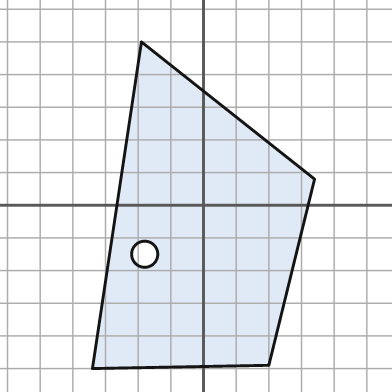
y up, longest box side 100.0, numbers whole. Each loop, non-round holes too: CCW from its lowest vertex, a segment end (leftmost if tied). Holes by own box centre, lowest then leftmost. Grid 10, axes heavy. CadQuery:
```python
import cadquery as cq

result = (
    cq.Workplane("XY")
    .moveTo(-34.0, -50.0)
    .lineTo(20.0, -49.0)
    .lineTo(34.0, 8.0)
    .lineTo(-19.0, 50.0)
    .close()
    .moveTo(-18.0, -15.0)
    .circle(4.0)
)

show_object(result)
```